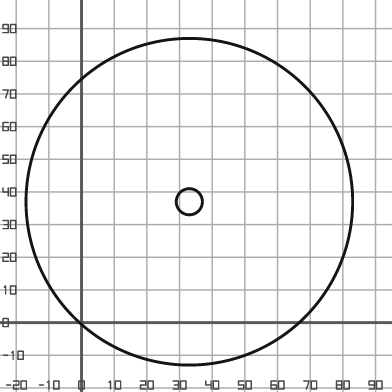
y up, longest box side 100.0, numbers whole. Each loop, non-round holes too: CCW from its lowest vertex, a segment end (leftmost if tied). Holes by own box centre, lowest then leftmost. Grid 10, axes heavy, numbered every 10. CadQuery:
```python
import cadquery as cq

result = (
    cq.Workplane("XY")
    .moveTo(33.0, 37.0)
    .circle(50.0)
    .moveTo(33.0, 37.0)
    .circle(4.0)
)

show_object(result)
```